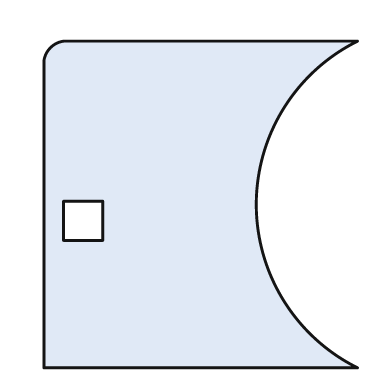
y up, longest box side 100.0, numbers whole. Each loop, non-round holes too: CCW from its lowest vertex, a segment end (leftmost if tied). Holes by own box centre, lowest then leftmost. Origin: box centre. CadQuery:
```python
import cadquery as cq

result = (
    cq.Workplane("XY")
    .moveTo(-48.0, -50.0)
    .lineTo(48.0, -50.0)
    .threePointArc((17.0, 0.0), (48.0, 50.0))
    .lineTo(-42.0, 50.0)
    .threePointArc((-46.0, 48.0), (-48.0, 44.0))
    .close()
    .moveTo(-42.0, -11.0)
    .lineTo(-30.0, -11.0)
    .lineTo(-30.0, 1.0)
    .lineTo(-42.0, 1.0)
    .close()
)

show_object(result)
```